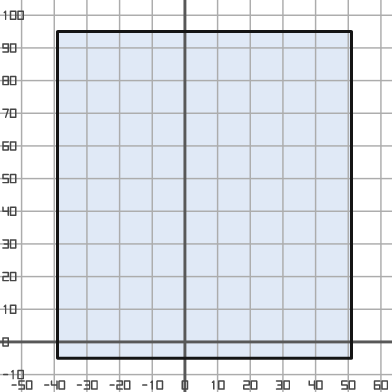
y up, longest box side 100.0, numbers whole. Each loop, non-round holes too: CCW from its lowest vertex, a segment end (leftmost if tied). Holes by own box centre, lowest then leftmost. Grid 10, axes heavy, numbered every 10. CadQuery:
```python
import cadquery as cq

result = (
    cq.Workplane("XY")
    .moveTo(-39.0, -5.0)
    .lineTo(51.0, -5.0)
    .lineTo(51.0, 95.0)
    .lineTo(-39.0, 95.0)
    .close()
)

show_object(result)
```